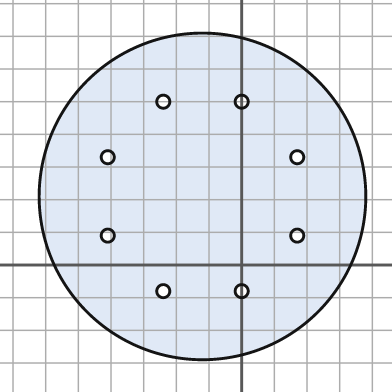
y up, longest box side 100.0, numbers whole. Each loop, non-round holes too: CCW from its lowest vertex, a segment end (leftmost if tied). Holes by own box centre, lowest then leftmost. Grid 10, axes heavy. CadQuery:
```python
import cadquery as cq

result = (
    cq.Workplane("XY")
    .moveTo(-12.0, 21.0)
    .circle(50.0)
    .moveTo(-24.0, -8.0)
    .circle(2.0)
    .moveTo(0.0, -8.0)
    .circle(2.0)
    .moveTo(-41.0, 9.0)
    .circle(2.0)
    .moveTo(17.0, 9.0)
    .circle(2.0)
    .moveTo(-41.0, 33.0)
    .circle(2.0)
    .moveTo(17.0, 33.0)
    .circle(2.0)
    .moveTo(-24.0, 50.0)
    .circle(2.0)
    .moveTo(0.0, 50.0)
    .circle(2.0)
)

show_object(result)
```